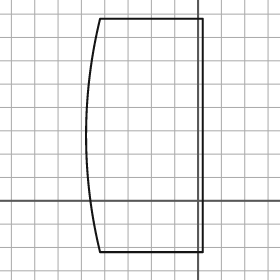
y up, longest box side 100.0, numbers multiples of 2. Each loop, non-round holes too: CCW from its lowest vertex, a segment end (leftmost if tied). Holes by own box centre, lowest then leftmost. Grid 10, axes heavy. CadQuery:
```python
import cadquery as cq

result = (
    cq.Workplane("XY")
    .moveTo(-42.0, -22.0)
    .lineTo(2.0, -22.0)
    .lineTo(2.0, 78.0)
    .lineTo(-42.0, 78.0)
    .threePointArc((-48.0, 28.0), (-42.0, -22.0))
    .close()
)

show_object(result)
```